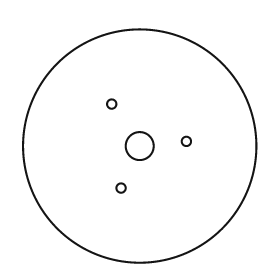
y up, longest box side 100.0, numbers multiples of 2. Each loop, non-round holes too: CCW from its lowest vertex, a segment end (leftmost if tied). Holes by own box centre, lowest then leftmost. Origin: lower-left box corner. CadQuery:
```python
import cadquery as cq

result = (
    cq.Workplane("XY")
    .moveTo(50.0, 50.0)
    .circle(50.0)
    .moveTo(42.0, 32.0)
    .circle(2.0)
    .moveTo(50.0, 50.0)
    .circle(6.0)
    .moveTo(70.0, 52.0)
    .circle(2.0)
    .moveTo(38.0, 68.0)
    .circle(2.0)
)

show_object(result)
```